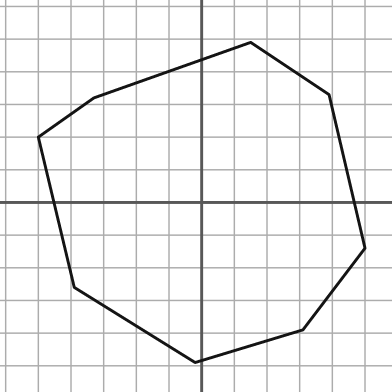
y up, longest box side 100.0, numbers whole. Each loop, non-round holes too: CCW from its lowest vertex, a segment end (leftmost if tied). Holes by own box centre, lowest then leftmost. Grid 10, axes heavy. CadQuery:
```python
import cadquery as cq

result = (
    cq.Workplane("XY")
    .moveTo(-2.0, -49.0)
    .lineTo(31.0, -39.0)
    .lineTo(50.0, -14.0)
    .lineTo(39.0, 33.0)
    .lineTo(15.0, 49.0)
    .lineTo(-33.0, 32.0)
    .lineTo(-50.0, 20.0)
    .lineTo(-39.0, -26.0)
    .close()
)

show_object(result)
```